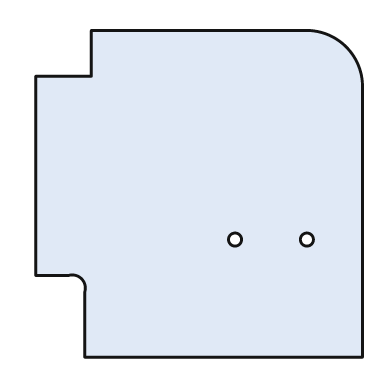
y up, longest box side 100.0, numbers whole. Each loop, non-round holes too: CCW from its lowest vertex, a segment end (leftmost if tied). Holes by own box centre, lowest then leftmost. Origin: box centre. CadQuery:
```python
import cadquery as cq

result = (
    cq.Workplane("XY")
    .moveTo(-35.0, -50.0)
    .lineTo(50.0, -50.0)
    .lineTo(50.0, 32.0)
    .threePointArc((45.0, 45.0), (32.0, 50.0))
    .lineTo(-33.0, 50.0)
    .lineTo(-33.0, 36.0)
    .lineTo(-50.0, 36.0)
    .lineTo(-50.0, -25.0)
    .lineTo(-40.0, -25.0)
    .threePointArc((-36.0, -26.0), (-35.0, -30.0))
    .close()
    .moveTo(11.0, -14.0)
    .circle(2.0)
    .moveTo(33.0, -14.0)
    .circle(2.0)
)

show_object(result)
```